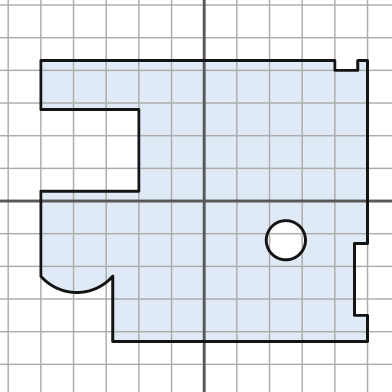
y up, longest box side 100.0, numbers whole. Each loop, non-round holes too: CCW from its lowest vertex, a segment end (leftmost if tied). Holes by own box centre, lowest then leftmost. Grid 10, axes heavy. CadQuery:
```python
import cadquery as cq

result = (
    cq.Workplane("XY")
    .moveTo(-28.0, -43.0)
    .lineTo(50.0, -43.0)
    .lineTo(50.0, -35.0)
    .lineTo(46.0, -35.0)
    .lineTo(46.0, -13.0)
    .lineTo(50.0, -13.0)
    .lineTo(50.0, 43.0)
    .lineTo(47.0, 43.0)
    .lineTo(47.0, 40.0)
    .lineTo(40.0, 40.0)
    .lineTo(40.0, 43.0)
    .lineTo(-50.0, 43.0)
    .lineTo(-50.0, 28.0)
    .lineTo(-20.0, 28.0)
    .lineTo(-20.0, 3.0)
    .lineTo(-50.0, 3.0)
    .lineTo(-50.0, -23.0)
    .threePointArc((-39.0, -28.0), (-28.0, -23.0))
    .close()
    .moveTo(25.0, -12.0)
    .circle(6.0)
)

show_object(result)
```